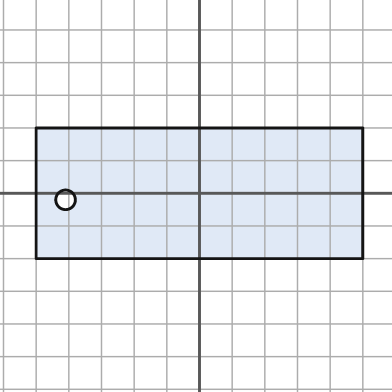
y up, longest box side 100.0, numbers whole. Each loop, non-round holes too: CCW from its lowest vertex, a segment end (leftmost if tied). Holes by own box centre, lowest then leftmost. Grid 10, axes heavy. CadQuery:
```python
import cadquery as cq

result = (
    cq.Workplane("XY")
    .moveTo(-50.0, -20.0)
    .lineTo(50.0, -20.0)
    .lineTo(50.0, 20.0)
    .lineTo(-50.0, 20.0)
    .close()
    .moveTo(-41.0, -2.0)
    .circle(3.0)
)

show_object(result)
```